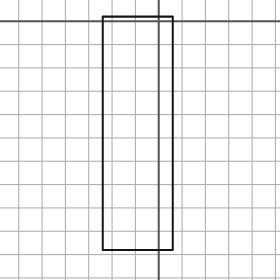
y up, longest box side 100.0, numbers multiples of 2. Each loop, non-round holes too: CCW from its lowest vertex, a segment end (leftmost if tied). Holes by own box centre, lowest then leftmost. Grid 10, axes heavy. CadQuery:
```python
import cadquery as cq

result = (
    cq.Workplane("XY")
    .moveTo(-24.0, -98.0)
    .lineTo(6.0, -98.0)
    .lineTo(6.0, 2.0)
    .lineTo(-24.0, 2.0)
    .close()
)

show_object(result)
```